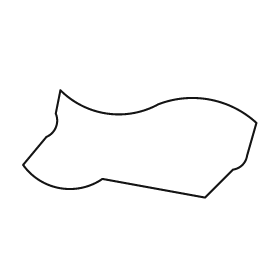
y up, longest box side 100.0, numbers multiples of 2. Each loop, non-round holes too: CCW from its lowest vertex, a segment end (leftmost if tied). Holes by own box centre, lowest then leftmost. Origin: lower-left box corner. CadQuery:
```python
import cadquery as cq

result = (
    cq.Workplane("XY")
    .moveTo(78.0, 0.0)
    .lineTo(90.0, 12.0)
    .threePointArc((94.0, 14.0), (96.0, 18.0))
    .lineTo(100.0, 32.0)
    .threePointArc((80.0, 42.0), (58.0, 40.0))
    .threePointArc((36.0, 36.0), (16.0, 46.0))
    .lineTo(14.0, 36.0)
    .threePointArc((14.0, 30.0), (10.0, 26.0))
    .lineTo(0.0, 14.0)
    .threePointArc((16.0, 4.0), (34.0, 8.0))
    .close()
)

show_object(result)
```